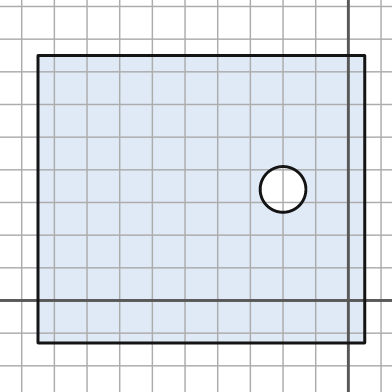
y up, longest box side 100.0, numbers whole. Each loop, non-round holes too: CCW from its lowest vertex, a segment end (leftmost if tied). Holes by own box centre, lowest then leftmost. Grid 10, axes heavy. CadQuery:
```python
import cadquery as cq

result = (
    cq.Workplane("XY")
    .moveTo(-95.0, -13.0)
    .lineTo(5.0, -13.0)
    .lineTo(5.0, 75.0)
    .lineTo(-95.0, 75.0)
    .close()
    .moveTo(-20.0, 34.0)
    .circle(7.0)
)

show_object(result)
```